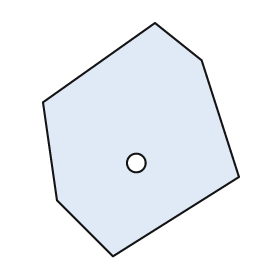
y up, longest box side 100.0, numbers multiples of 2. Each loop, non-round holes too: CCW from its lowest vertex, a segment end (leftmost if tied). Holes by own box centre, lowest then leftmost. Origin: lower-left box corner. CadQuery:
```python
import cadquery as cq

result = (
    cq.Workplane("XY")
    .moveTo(30.0, 0.0)
    .lineTo(84.0, 34.0)
    .lineTo(68.0, 84.0)
    .lineTo(48.0, 100.0)
    .lineTo(0.0, 66.0)
    .lineTo(6.0, 24.0)
    .close()
    .moveTo(40.0, 40.0)
    .circle(4.0)
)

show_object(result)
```